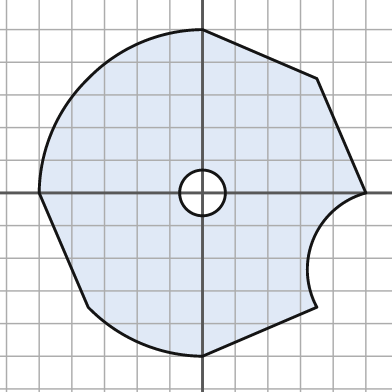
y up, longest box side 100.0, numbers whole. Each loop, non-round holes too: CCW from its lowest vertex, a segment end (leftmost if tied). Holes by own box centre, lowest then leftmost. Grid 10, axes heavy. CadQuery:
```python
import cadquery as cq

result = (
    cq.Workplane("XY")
    .moveTo(0.0, -50.0)
    .lineTo(35.0, -35.0)
    .threePointArc((34.0, -14.0), (50.0, 0.0))
    .lineTo(35.0, 35.0)
    .lineTo(0.0, 50.0)
    .threePointArc((-19.0, 46.0), (-35.0, 35.0))
    .threePointArc((-46.0, 19.0), (-50.0, 0.0))
    .lineTo(-35.0, -35.0)
    .threePointArc((-19.0, -46.0), (0.0, -50.0))
    .close()
    .moveTo(0.0, 0.0)
    .circle(7.0)
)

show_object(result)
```